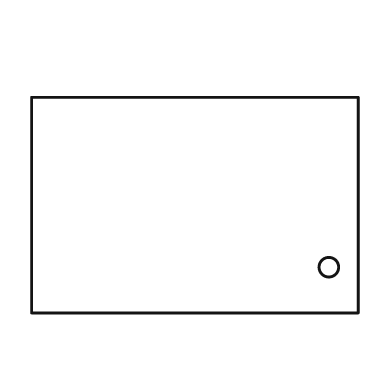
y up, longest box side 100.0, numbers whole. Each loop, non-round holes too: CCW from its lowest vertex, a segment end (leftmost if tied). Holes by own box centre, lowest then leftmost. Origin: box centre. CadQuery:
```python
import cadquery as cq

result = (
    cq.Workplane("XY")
    .moveTo(-50.0, -33.0)
    .lineTo(50.0, -33.0)
    .lineTo(50.0, 33.0)
    .lineTo(-50.0, 33.0)
    .close()
    .moveTo(41.0, -19.0)
    .circle(3.0)
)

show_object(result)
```